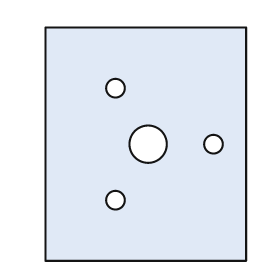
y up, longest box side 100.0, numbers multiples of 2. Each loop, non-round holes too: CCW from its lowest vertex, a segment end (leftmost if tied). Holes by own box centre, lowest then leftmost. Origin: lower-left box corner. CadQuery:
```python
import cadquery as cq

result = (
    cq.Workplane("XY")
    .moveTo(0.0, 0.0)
    .lineTo(86.0, 0.0)
    .lineTo(86.0, 100.0)
    .lineTo(0.0, 100.0)
    .close()
    .moveTo(30.0, 26.0)
    .circle(4.0)
    .moveTo(44.0, 50.0)
    .circle(8.0)
    .moveTo(72.0, 50.0)
    .circle(4.0)
    .moveTo(30.0, 74.0)
    .circle(4.0)
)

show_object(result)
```